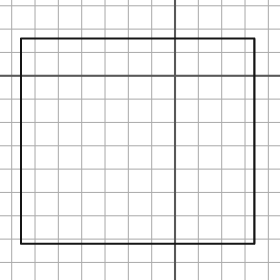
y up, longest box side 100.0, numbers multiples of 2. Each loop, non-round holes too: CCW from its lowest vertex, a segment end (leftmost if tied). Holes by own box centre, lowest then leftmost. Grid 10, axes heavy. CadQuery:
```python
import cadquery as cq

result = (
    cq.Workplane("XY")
    .moveTo(-66.0, -72.0)
    .lineTo(34.0, -72.0)
    .lineTo(34.0, 16.0)
    .lineTo(-66.0, 16.0)
    .close()
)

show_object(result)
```